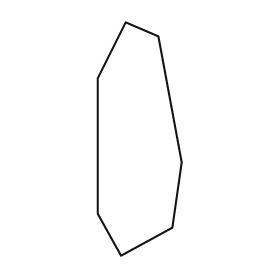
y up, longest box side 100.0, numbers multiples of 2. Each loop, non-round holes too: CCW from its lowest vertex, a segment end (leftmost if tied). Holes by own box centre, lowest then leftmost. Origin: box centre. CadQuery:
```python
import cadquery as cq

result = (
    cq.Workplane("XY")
    .moveTo(-8.0, -50.0)
    .lineTo(14.0, -38.0)
    .lineTo(18.0, -10.0)
    .lineTo(8.0, 44.0)
    .lineTo(-6.0, 50.0)
    .lineTo(-18.0, 26.0)
    .lineTo(-18.0, -32.0)
    .close()
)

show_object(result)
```